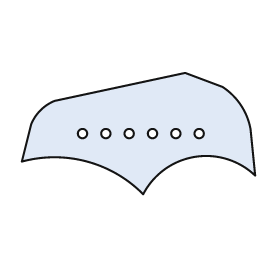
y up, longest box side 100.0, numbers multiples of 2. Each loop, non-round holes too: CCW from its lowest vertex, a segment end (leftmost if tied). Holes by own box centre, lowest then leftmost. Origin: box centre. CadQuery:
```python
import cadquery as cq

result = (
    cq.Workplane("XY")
    .moveTo(2.0, -26.0)
    .threePointArc((24.0, -10.0), (50.0, -18.0))
    .lineTo(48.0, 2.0)
    .threePointArc((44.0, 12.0), (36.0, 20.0))
    .lineTo(20.0, 26.0)
    .lineTo(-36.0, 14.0)
    .threePointArc((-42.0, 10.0), (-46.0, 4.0))
    .lineTo(-50.0, -12.0)
    .threePointArc((-22.0, -12.0), (2.0, -26.0))
    .close()
    .moveTo(-24.0, 0.0)
    .circle(2.0)
    .moveTo(-14.0, 0.0)
    .circle(2.0)
    .moveTo(-4.0, 0.0)
    .circle(2.0)
    .moveTo(6.0, 0.0)
    .circle(2.0)
    .moveTo(16.0, 0.0)
    .circle(2.0)
    .moveTo(26.0, 0.0)
    .circle(2.0)
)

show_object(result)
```